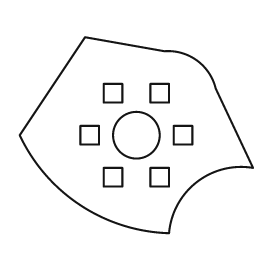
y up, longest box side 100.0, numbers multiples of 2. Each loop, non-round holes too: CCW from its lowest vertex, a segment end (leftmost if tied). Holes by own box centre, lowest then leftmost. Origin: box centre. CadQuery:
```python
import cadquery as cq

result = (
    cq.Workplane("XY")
    .moveTo(14.0, -42.0)
    .threePointArc((26.0, -20.0), (50.0, -14.0))
    .lineTo(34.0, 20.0)
    .threePointArc((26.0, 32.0), (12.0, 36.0))
    .lineTo(-22.0, 42.0)
    .lineTo(-50.0, 0.0)
    .threePointArc((-24.0, -30.0), (14.0, -42.0))
    .close()
    .moveTo(-14.0, -22.0)
    .lineTo(-6.0, -22.0)
    .lineTo(-6.0, -14.0)
    .lineTo(-14.0, -14.0)
    .close()
    .moveTo(6.0, -22.0)
    .lineTo(14.0, -22.0)
    .lineTo(14.0, -14.0)
    .lineTo(6.0, -14.0)
    .close()
    .moveTo(-24.0, -4.0)
    .lineTo(-16.0, -4.0)
    .lineTo(-16.0, 4.0)
    .lineTo(-24.0, 4.0)
    .close()
    .moveTo(0.0, 0.0)
    .circle(10.0)
    .moveTo(16.0, -4.0)
    .lineTo(24.0, -4.0)
    .lineTo(24.0, 4.0)
    .lineTo(16.0, 4.0)
    .close()
    .moveTo(-14.0, 14.0)
    .lineTo(-6.0, 14.0)
    .lineTo(-6.0, 22.0)
    .lineTo(-14.0, 22.0)
    .close()
    .moveTo(6.0, 14.0)
    .lineTo(14.0, 14.0)
    .lineTo(14.0, 22.0)
    .lineTo(6.0, 22.0)
    .close()
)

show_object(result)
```